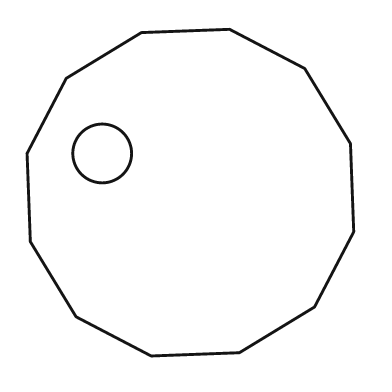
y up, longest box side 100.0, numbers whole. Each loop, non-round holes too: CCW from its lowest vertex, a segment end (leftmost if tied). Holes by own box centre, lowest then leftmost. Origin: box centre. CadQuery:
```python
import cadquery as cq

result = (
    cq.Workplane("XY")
    .moveTo(-12.0, -50.0)
    .lineTo(15.0, -49.0)
    .lineTo(38.0, -35.0)
    .lineTo(50.0, -12.0)
    .lineTo(49.0, 15.0)
    .lineTo(35.0, 38.0)
    .lineTo(12.0, 50.0)
    .lineTo(-15.0, 49.0)
    .lineTo(-38.0, 35.0)
    .lineTo(-50.0, 12.0)
    .lineTo(-49.0, -15.0)
    .lineTo(-35.0, -38.0)
    .close()
    .moveTo(-27.0, 12.0)
    .circle(9.0)
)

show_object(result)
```